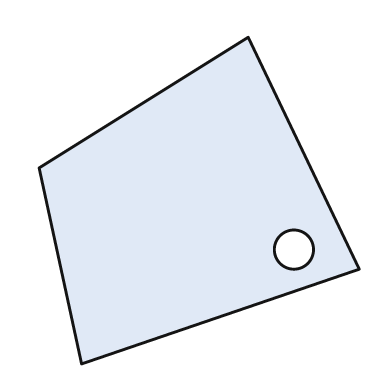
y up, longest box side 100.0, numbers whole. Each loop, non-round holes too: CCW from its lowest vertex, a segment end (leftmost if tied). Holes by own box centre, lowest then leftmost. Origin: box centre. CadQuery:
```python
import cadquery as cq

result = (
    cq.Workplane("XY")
    .moveTo(-36.0, -50.0)
    .lineTo(49.0, -21.0)
    .lineTo(15.0, 50.0)
    .lineTo(-49.0, 10.0)
    .close()
    .moveTo(29.0, -15.0)
    .circle(6.0)
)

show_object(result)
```